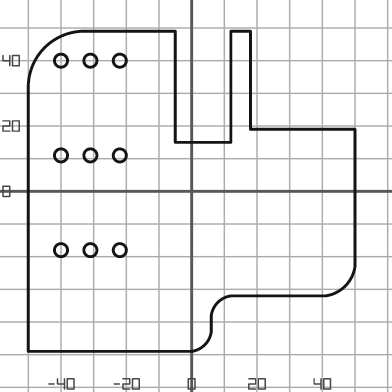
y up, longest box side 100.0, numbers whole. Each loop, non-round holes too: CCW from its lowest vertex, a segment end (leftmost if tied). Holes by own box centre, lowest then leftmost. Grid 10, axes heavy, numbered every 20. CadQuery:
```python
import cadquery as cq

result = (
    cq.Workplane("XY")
    .moveTo(-50.0, -49.0)
    .lineTo(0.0, -49.0)
    .threePointArc((4.0, -47.0), (6.0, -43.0))
    .lineTo(6.0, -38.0)
    .threePointArc((8.0, -34.0), (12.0, -32.0))
    .lineTo(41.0, -32.0)
    .threePointArc((47.0, -29.0), (50.0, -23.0))
    .lineTo(50.0, 19.0)
    .lineTo(18.0, 19.0)
    .lineTo(18.0, 49.0)
    .lineTo(12.0, 49.0)
    .lineTo(12.0, 15.0)
    .lineTo(-5.0, 15.0)
    .lineTo(-5.0, 49.0)
    .lineTo(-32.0, 49.0)
    .threePointArc((-45.0, 44.0), (-50.0, 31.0))
    .close()
    .moveTo(-40.0, -18.0)
    .circle(2.0)
    .moveTo(-31.0, -18.0)
    .circle(2.0)
    .moveTo(-22.0, -18.0)
    .circle(2.0)
    .moveTo(-40.0, 11.0)
    .circle(2.0)
    .moveTo(-31.0, 11.0)
    .circle(2.0)
    .moveTo(-22.0, 11.0)
    .circle(2.0)
    .moveTo(-40.0, 40.0)
    .circle(2.0)
    .moveTo(-31.0, 40.0)
    .circle(2.0)
    .moveTo(-22.0, 40.0)
    .circle(2.0)
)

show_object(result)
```